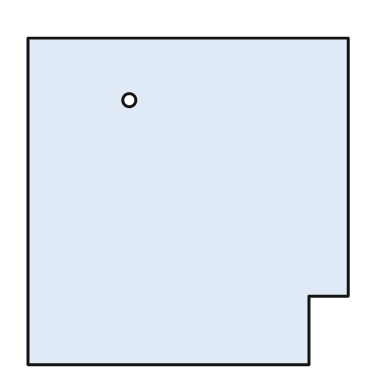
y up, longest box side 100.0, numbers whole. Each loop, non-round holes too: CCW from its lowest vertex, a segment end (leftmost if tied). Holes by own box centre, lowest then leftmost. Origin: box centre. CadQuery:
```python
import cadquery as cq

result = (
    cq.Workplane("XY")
    .moveTo(-49.0, -50.0)
    .lineTo(37.0, -50.0)
    .lineTo(37.0, -29.0)
    .lineTo(49.0, -29.0)
    .lineTo(49.0, 50.0)
    .lineTo(-49.0, 50.0)
    .close()
    .moveTo(-18.0, 31.0)
    .circle(2.0)
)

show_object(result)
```